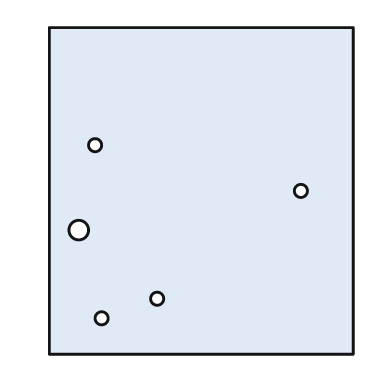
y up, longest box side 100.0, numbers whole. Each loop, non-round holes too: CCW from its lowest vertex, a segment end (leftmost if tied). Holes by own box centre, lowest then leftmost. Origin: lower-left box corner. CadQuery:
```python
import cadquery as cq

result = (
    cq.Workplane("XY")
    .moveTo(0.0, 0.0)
    .lineTo(93.0, 0.0)
    .lineTo(93.0, 100.0)
    .lineTo(0.0, 100.0)
    .close()
    .moveTo(16.0, 11.0)
    .circle(2.0)
    .moveTo(33.0, 17.0)
    .circle(2.0)
    .moveTo(9.0, 38.0)
    .circle(3.0)
    .moveTo(77.0, 50.0)
    .circle(2.0)
    .moveTo(14.0, 64.0)
    .circle(2.0)
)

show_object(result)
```